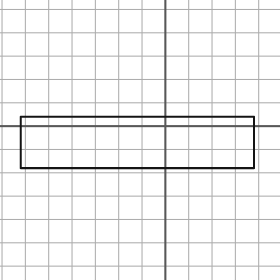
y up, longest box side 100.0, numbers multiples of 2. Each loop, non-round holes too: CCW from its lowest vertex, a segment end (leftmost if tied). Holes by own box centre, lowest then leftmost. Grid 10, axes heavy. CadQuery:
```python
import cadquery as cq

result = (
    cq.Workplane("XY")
    .moveTo(-62.0, -18.0)
    .lineTo(38.0, -18.0)
    .lineTo(38.0, 4.0)
    .lineTo(-62.0, 4.0)
    .close()
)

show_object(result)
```